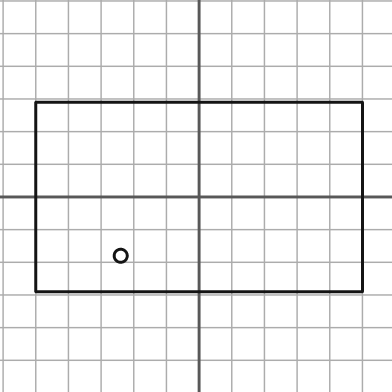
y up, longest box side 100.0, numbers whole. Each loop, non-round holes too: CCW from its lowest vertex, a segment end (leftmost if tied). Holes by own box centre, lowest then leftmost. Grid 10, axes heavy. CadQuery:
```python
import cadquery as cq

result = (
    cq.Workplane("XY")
    .moveTo(-50.0, -29.0)
    .lineTo(50.0, -29.0)
    .lineTo(50.0, 29.0)
    .lineTo(-50.0, 29.0)
    .close()
    .moveTo(-24.0, -18.0)
    .circle(2.0)
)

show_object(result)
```